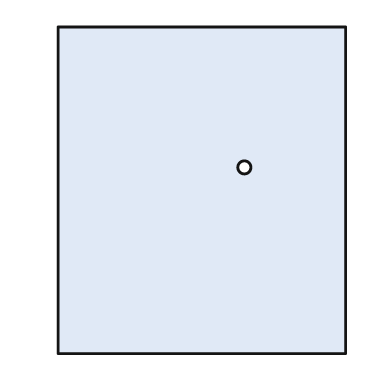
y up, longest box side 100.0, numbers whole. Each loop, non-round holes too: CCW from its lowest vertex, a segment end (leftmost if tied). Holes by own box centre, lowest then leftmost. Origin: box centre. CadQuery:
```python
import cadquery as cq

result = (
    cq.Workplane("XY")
    .moveTo(-44.0, -50.0)
    .lineTo(44.0, -50.0)
    .lineTo(44.0, 50.0)
    .lineTo(-44.0, 50.0)
    .close()
    .moveTo(13.0, 7.0)
    .circle(2.0)
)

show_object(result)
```